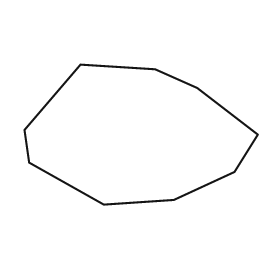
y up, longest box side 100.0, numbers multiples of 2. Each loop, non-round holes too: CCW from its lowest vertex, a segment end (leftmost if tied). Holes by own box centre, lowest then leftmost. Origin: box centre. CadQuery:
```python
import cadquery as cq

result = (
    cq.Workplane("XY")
    .moveTo(-16.0, -30.0)
    .lineTo(14.0, -28.0)
    .lineTo(40.0, -16.0)
    .lineTo(50.0, 0.0)
    .lineTo(24.0, 20.0)
    .lineTo(6.0, 28.0)
    .lineTo(-26.0, 30.0)
    .lineTo(-50.0, 2.0)
    .lineTo(-48.0, -12.0)
    .close()
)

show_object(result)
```